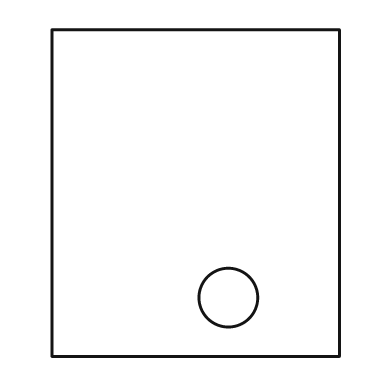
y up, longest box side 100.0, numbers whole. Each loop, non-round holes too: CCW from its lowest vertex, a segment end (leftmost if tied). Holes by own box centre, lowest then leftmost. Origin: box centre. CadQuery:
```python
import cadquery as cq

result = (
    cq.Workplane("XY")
    .moveTo(-44.0, -50.0)
    .lineTo(44.0, -50.0)
    .lineTo(44.0, 50.0)
    .lineTo(-44.0, 50.0)
    .close()
    .moveTo(10.0, -32.0)
    .circle(9.0)
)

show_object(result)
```